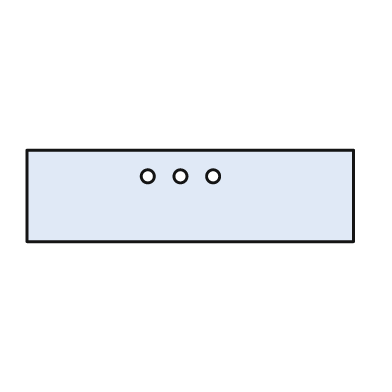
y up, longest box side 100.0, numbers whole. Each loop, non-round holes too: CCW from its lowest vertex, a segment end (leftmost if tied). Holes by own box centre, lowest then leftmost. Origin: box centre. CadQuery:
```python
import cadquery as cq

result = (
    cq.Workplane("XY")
    .moveTo(-50.0, -14.0)
    .lineTo(50.0, -14.0)
    .lineTo(50.0, 14.0)
    .lineTo(-50.0, 14.0)
    .close()
    .moveTo(-13.0, 6.0)
    .circle(2.0)
    .moveTo(-3.0, 6.0)
    .circle(2.0)
    .moveTo(7.0, 6.0)
    .circle(2.0)
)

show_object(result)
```